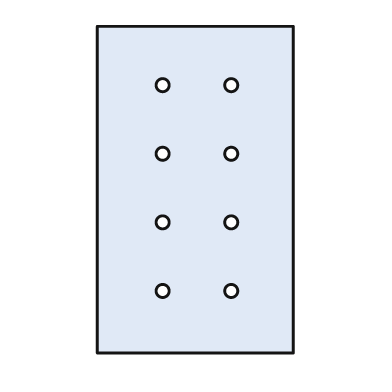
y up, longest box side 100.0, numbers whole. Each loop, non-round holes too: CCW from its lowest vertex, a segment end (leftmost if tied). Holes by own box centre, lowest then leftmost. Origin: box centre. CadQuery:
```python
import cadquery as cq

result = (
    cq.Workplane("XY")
    .moveTo(-30.0, -50.0)
    .lineTo(30.0, -50.0)
    .lineTo(30.0, 50.0)
    .lineTo(-30.0, 50.0)
    .close()
    .moveTo(-10.0, -31.0)
    .circle(2.0)
    .moveTo(11.0, -31.0)
    .circle(2.0)
    .moveTo(-10.0, -10.0)
    .circle(2.0)
    .moveTo(11.0, -10.0)
    .circle(2.0)
    .moveTo(-10.0, 11.0)
    .circle(2.0)
    .moveTo(11.0, 11.0)
    .circle(2.0)
    .moveTo(-10.0, 32.0)
    .circle(2.0)
    .moveTo(11.0, 32.0)
    .circle(2.0)
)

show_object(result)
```